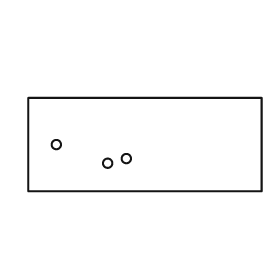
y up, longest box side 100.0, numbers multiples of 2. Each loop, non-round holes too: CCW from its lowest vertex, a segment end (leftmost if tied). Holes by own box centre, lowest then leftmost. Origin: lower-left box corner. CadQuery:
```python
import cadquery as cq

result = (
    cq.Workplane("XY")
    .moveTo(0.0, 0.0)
    .lineTo(100.0, 0.0)
    .lineTo(100.0, 40.0)
    .lineTo(0.0, 40.0)
    .close()
    .moveTo(34.0, 12.0)
    .circle(2.0)
    .moveTo(42.0, 14.0)
    .circle(2.0)
    .moveTo(12.0, 20.0)
    .circle(2.0)
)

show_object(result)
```